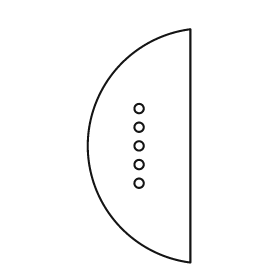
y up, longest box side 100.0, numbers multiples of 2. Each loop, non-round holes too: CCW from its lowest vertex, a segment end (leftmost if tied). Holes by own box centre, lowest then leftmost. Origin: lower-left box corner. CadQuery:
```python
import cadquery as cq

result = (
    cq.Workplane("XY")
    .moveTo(44.0, 0.0)
    .lineTo(44.0, 100.0)
    .threePointArc((0.0, 50.0), (44.0, 0.0))
    .close()
    .moveTo(22.0, 34.0)
    .circle(2.0)
    .moveTo(22.0, 42.0)
    .circle(2.0)
    .moveTo(22.0, 50.0)
    .circle(2.0)
    .moveTo(22.0, 58.0)
    .circle(2.0)
    .moveTo(22.0, 66.0)
    .circle(2.0)
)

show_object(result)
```